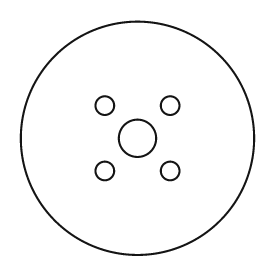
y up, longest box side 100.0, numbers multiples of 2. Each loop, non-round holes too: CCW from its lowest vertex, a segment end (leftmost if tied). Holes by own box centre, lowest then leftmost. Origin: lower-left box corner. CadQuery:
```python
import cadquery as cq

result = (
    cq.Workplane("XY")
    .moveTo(50.0, 50.0)
    .circle(50.0)
    .moveTo(36.0, 36.0)
    .circle(4.0)
    .moveTo(64.0, 36.0)
    .circle(4.0)
    .moveTo(50.0, 50.0)
    .circle(8.0)
    .moveTo(36.0, 64.0)
    .circle(4.0)
    .moveTo(64.0, 64.0)
    .circle(4.0)
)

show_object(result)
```